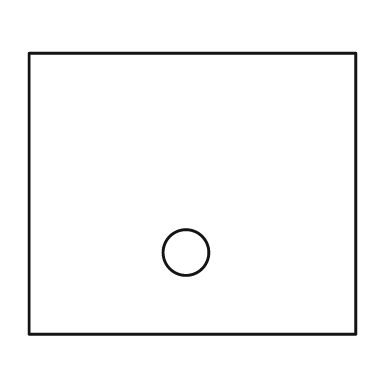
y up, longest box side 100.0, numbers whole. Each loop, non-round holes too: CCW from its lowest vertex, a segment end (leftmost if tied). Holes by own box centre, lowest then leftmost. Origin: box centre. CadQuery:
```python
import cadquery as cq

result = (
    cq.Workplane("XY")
    .moveTo(-50.0, -43.0)
    .lineTo(50.0, -43.0)
    .lineTo(50.0, 43.0)
    .lineTo(-50.0, 43.0)
    .close()
    .moveTo(-2.0, -18.0)
    .circle(7.0)
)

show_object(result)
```